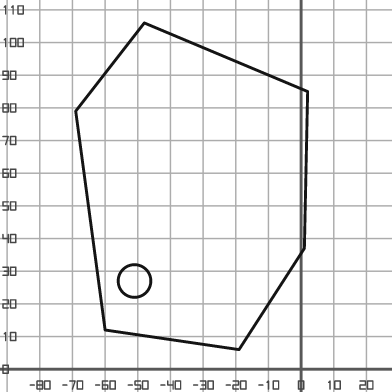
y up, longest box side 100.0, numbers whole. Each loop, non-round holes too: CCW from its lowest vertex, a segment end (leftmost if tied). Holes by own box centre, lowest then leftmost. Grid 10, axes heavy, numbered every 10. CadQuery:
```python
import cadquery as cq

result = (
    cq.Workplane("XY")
    .moveTo(-19.0, 6.0)
    .lineTo(1.0, 37.0)
    .lineTo(2.0, 85.0)
    .lineTo(-48.0, 106.0)
    .lineTo(-69.0, 79.0)
    .lineTo(-60.0, 12.0)
    .close()
    .moveTo(-51.0, 27.0)
    .circle(5.0)
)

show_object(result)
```